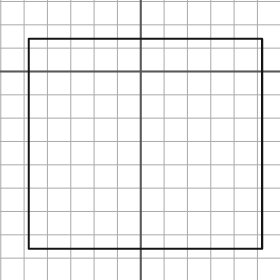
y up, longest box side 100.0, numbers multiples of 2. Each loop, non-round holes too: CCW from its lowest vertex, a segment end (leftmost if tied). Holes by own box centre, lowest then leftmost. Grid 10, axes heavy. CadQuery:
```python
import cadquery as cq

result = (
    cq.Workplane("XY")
    .moveTo(-48.0, -76.0)
    .lineTo(52.0, -76.0)
    .lineTo(52.0, 14.0)
    .lineTo(-48.0, 14.0)
    .close()
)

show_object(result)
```